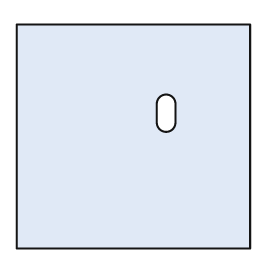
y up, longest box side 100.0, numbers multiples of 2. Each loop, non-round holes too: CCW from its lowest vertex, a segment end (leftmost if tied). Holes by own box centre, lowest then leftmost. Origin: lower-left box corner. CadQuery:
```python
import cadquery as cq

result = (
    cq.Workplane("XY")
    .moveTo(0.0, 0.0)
    .lineTo(100.0, 0.0)
    .lineTo(100.0, 96.0)
    .lineTo(0.0, 96.0)
    .close()
    .moveTo(60.0, 54.0)
    .threePointArc((64.0, 50.0), (68.0, 54.0))
    .lineTo(68.0, 62.0)
    .threePointArc((64.0, 66.0), (60.0, 62.0))
    .close()
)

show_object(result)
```